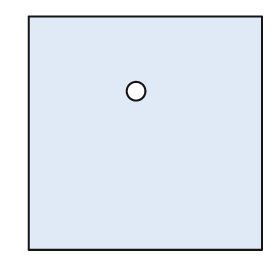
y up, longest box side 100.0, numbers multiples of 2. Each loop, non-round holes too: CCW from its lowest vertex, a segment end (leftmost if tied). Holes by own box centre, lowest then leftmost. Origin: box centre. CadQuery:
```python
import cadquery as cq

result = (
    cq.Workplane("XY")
    .moveTo(-50.0, -50.0)
    .lineTo(50.0, -50.0)
    .lineTo(50.0, 50.0)
    .lineTo(-50.0, 50.0)
    .close()
    .moveTo(-4.0, 18.0)
    .circle(4.0)
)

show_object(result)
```